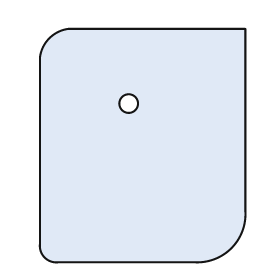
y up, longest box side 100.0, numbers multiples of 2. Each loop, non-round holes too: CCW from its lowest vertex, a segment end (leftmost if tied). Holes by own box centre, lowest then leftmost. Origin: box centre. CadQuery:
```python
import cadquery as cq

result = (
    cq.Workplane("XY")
    .moveTo(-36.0, -50.0)
    .lineTo(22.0, -50.0)
    .threePointArc((38.0, -44.0), (44.0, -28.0))
    .lineTo(44.0, 50.0)
    .lineTo(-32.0, 50.0)
    .threePointArc((-40.0, 46.0), (-44.0, 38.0))
    .lineTo(-44.0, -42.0)
    .threePointArc((-42.0, -48.0), (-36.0, -50.0))
    .close()
    .moveTo(-6.0, 18.0)
    .circle(4.0)
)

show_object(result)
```